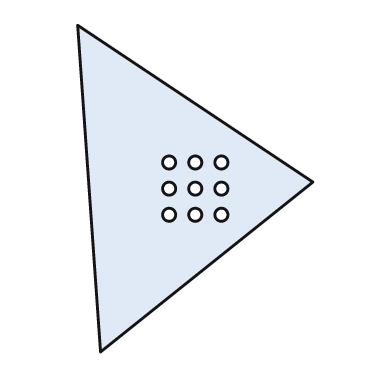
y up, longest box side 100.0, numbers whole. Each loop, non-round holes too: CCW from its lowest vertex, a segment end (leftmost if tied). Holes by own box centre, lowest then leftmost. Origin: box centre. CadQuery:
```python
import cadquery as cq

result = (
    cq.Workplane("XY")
    .moveTo(-29.0, -50.0)
    .lineTo(36.0, 2.0)
    .lineTo(-36.0, 50.0)
    .close()
    .moveTo(-8.0, -8.0)
    .circle(2.0)
    .moveTo(0.0, -8.0)
    .circle(2.0)
    .moveTo(8.0, -8.0)
    .circle(2.0)
    .moveTo(-8.0, 0.0)
    .circle(2.0)
    .moveTo(0.0, 0.0)
    .circle(2.0)
    .moveTo(8.0, 0.0)
    .circle(2.0)
    .moveTo(-8.0, 8.0)
    .circle(2.0)
    .moveTo(0.0, 8.0)
    .circle(2.0)
    .moveTo(8.0, 8.0)
    .circle(2.0)
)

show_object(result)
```